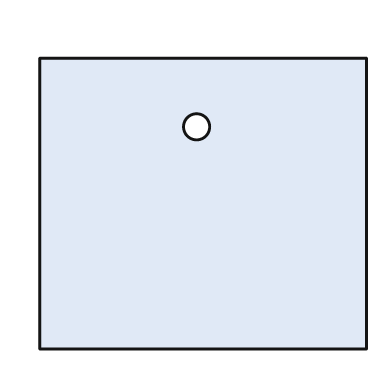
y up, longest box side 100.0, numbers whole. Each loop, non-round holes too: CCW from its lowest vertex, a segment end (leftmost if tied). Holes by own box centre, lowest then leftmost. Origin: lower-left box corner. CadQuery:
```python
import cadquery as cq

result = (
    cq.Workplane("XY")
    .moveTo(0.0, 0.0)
    .lineTo(100.0, 0.0)
    .lineTo(100.0, 89.0)
    .lineTo(0.0, 89.0)
    .close()
    .moveTo(48.0, 68.0)
    .circle(4.0)
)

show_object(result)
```